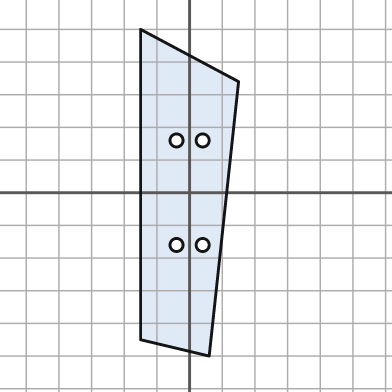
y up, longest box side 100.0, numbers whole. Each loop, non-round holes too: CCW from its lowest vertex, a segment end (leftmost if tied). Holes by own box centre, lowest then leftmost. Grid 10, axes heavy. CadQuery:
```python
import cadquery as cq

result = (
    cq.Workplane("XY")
    .moveTo(6.0, -50.0)
    .lineTo(15.0, 34.0)
    .lineTo(-15.0, 50.0)
    .lineTo(-15.0, -45.0)
    .close()
    .moveTo(-4.0, -16.0)
    .circle(2.0)
    .moveTo(4.0, -16.0)
    .circle(2.0)
    .moveTo(-4.0, 16.0)
    .circle(2.0)
    .moveTo(4.0, 16.0)
    .circle(2.0)
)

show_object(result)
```